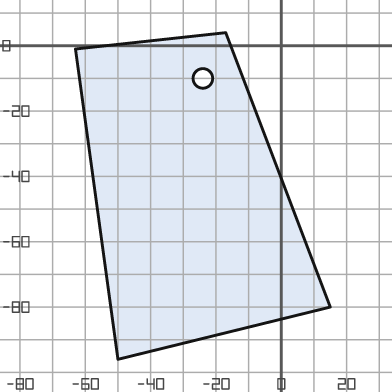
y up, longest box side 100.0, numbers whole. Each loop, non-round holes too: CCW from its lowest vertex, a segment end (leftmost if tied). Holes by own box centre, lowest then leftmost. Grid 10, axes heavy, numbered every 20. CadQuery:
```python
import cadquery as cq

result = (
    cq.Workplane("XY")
    .moveTo(-50.0, -96.0)
    .lineTo(15.0, -80.0)
    .lineTo(-17.0, 4.0)
    .lineTo(-63.0, -1.0)
    .close()
    .moveTo(-24.0, -10.0)
    .circle(3.0)
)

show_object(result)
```